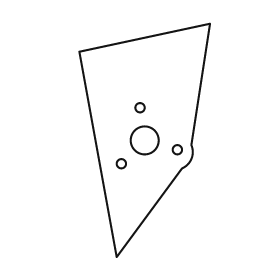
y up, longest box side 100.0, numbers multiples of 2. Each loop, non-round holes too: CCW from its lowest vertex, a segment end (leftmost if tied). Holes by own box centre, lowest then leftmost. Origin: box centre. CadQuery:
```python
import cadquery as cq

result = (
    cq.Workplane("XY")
    .moveTo(-12.0, -50.0)
    .lineTo(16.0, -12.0)
    .threePointArc((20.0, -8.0), (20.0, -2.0))
    .lineTo(28.0, 50.0)
    .lineTo(-28.0, 38.0)
    .close()
    .moveTo(-10.0, -10.0)
    .circle(2.0)
    .moveTo(14.0, -4.0)
    .circle(2.0)
    .moveTo(0.0, 0.0)
    .circle(6.0)
    .moveTo(-2.0, 14.0)
    .circle(2.0)
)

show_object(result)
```